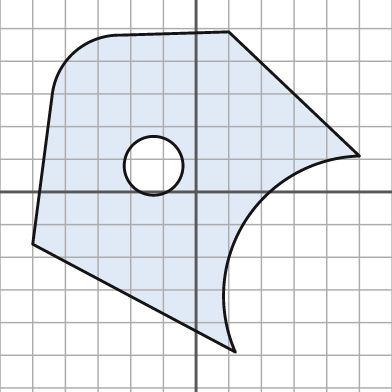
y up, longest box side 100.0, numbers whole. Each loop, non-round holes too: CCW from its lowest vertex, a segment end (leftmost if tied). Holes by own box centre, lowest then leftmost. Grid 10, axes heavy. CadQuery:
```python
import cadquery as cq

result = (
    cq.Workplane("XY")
    .moveTo(12.0, -49.0)
    .threePointArc((15.0, -9.0), (50.0, 11.0))
    .lineTo(10.0, 49.0)
    .lineTo(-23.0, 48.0)
    .threePointArc((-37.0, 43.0), (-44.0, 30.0))
    .lineTo(-50.0, -16.0)
    .close()
    .moveTo(-13.0, 8.0)
    .circle(9.0)
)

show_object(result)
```